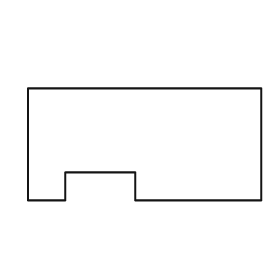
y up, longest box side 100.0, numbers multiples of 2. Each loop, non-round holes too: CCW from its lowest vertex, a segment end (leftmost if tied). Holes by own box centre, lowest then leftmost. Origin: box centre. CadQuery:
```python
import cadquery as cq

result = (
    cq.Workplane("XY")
    .moveTo(-50.0, -24.0)
    .lineTo(-34.0, -24.0)
    .lineTo(-34.0, -12.0)
    .lineTo(-4.0, -12.0)
    .lineTo(-4.0, -24.0)
    .lineTo(50.0, -24.0)
    .lineTo(50.0, 24.0)
    .lineTo(-50.0, 24.0)
    .close()
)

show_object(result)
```